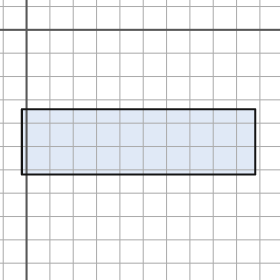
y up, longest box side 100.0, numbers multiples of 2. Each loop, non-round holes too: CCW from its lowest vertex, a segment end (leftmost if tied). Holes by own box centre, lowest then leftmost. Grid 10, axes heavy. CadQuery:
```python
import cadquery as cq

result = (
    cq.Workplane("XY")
    .moveTo(-2.0, -62.0)
    .lineTo(98.0, -62.0)
    .lineTo(98.0, -34.0)
    .lineTo(-2.0, -34.0)
    .close()
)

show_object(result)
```